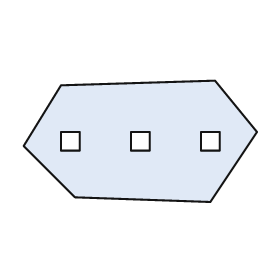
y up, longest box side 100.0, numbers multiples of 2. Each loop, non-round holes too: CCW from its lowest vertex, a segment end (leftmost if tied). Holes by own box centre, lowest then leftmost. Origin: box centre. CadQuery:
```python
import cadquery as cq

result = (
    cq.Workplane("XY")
    .moveTo(30.0, -26.0)
    .lineTo(50.0, 4.0)
    .lineTo(32.0, 26.0)
    .lineTo(-34.0, 24.0)
    .lineTo(-50.0, -2.0)
    .lineTo(-28.0, -24.0)
    .close()
    .moveTo(-34.0, -4.0)
    .lineTo(-26.0, -4.0)
    .lineTo(-26.0, 4.0)
    .lineTo(-34.0, 4.0)
    .close()
    .moveTo(-4.0, -4.0)
    .lineTo(4.0, -4.0)
    .lineTo(4.0, 4.0)
    .lineTo(-4.0, 4.0)
    .close()
    .moveTo(26.0, -4.0)
    .lineTo(34.0, -4.0)
    .lineTo(34.0, 4.0)
    .lineTo(26.0, 4.0)
    .close()
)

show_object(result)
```